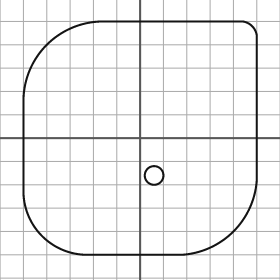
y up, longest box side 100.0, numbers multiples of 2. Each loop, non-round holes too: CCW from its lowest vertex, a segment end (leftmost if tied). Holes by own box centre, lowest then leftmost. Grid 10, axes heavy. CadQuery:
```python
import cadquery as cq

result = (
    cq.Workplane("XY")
    .moveTo(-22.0, -50.0)
    .lineTo(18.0, -50.0)
    .threePointArc((40.0, -40.0), (50.0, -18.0))
    .lineTo(50.0, 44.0)
    .threePointArc((48.0, 48.0), (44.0, 50.0))
    .lineTo(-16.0, 50.0)
    .threePointArc((-40.0, 40.0), (-50.0, 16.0))
    .lineTo(-50.0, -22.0)
    .threePointArc((-42.0, -42.0), (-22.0, -50.0))
    .close()
    .moveTo(6.0, -16.0)
    .circle(4.0)
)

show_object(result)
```